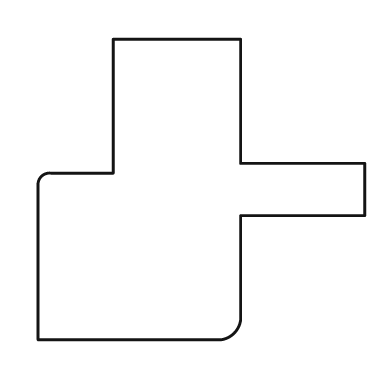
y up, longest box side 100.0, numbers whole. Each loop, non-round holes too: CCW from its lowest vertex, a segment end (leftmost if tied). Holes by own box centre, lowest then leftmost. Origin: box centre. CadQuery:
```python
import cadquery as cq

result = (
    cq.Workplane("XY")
    .moveTo(-50.0, -46.0)
    .lineTo(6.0, -46.0)
    .threePointArc((10.0, -44.0), (12.0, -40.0))
    .lineTo(12.0, -8.0)
    .lineTo(50.0, -8.0)
    .lineTo(50.0, 8.0)
    .lineTo(12.0, 8.0)
    .lineTo(12.0, 46.0)
    .lineTo(-27.0, 46.0)
    .lineTo(-27.0, 5.0)
    .lineTo(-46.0, 5.0)
    .threePointArc((-49.0, 4.0), (-50.0, 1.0))
    .close()
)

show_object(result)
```